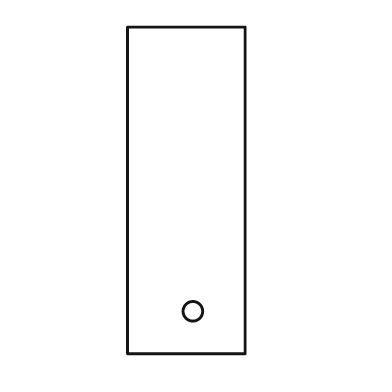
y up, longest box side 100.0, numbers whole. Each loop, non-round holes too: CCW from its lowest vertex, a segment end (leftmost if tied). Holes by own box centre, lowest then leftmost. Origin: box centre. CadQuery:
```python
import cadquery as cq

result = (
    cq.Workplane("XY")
    .moveTo(-18.0, -50.0)
    .lineTo(18.0, -50.0)
    .lineTo(18.0, 50.0)
    .lineTo(-18.0, 50.0)
    .close()
    .moveTo(2.0, -37.0)
    .circle(3.0)
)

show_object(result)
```